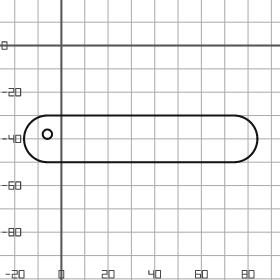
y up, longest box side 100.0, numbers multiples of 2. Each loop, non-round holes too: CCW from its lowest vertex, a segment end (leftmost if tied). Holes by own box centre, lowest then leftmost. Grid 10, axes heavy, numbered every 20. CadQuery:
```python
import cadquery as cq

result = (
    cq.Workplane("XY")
    .moveTo(-6.0, -50.0)
    .lineTo(74.0, -50.0)
    .threePointArc((84.0, -40.0), (74.0, -30.0))
    .lineTo(-6.0, -30.0)
    .threePointArc((-16.0, -40.0), (-6.0, -50.0))
    .close()
    .moveTo(-6.0, -38.0)
    .circle(2.0)
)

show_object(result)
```